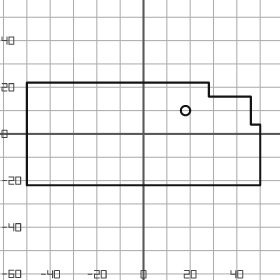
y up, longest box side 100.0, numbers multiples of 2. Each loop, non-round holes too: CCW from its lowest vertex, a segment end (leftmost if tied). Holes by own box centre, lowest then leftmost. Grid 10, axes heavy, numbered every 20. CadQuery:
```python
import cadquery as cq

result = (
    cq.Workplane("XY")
    .moveTo(-50.0, -22.0)
    .lineTo(50.0, -22.0)
    .lineTo(50.0, 4.0)
    .lineTo(46.0, 4.0)
    .lineTo(46.0, 16.0)
    .lineTo(28.0, 16.0)
    .lineTo(28.0, 22.0)
    .lineTo(-50.0, 22.0)
    .close()
    .moveTo(18.0, 10.0)
    .circle(2.0)
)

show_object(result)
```